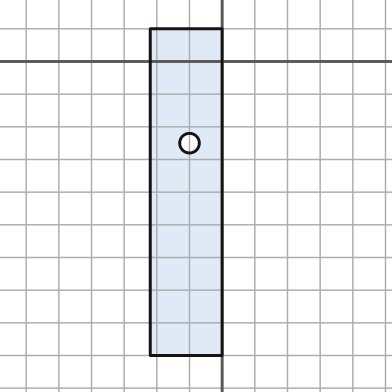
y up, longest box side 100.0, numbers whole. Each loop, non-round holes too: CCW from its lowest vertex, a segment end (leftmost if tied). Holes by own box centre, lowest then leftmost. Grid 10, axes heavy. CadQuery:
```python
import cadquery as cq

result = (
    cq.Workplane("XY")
    .moveTo(-22.0, -90.0)
    .lineTo(0.0, -90.0)
    .lineTo(0.0, 10.0)
    .lineTo(-22.0, 10.0)
    .close()
    .moveTo(-10.0, -25.0)
    .circle(3.0)
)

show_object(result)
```